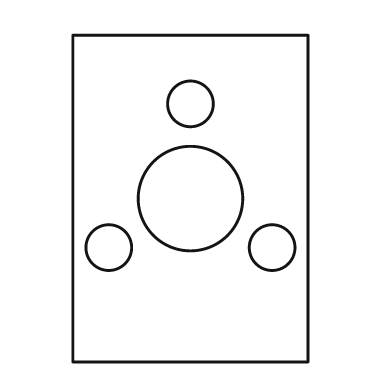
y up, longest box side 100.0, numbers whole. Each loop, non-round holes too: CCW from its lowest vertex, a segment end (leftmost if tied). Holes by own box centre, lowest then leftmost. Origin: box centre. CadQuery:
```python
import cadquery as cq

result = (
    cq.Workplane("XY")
    .moveTo(-36.0, -50.0)
    .lineTo(36.0, -50.0)
    .lineTo(36.0, 50.0)
    .lineTo(-36.0, 50.0)
    .close()
    .moveTo(-25.0, -15.0)
    .circle(7.0)
    .moveTo(25.0, -15.0)
    .circle(7.0)
    .moveTo(0.0, 0.0)
    .circle(16.0)
    .moveTo(0.0, 29.0)
    .circle(7.0)
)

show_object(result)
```